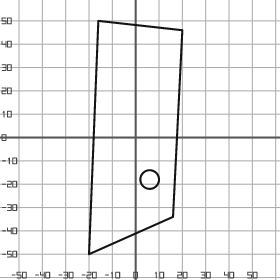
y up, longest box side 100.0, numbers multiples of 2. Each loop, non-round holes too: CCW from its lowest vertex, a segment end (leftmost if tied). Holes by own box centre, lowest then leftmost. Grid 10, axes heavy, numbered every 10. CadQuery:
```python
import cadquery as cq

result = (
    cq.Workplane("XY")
    .moveTo(-20.0, -50.0)
    .lineTo(16.0, -34.0)
    .lineTo(20.0, 46.0)
    .lineTo(-16.0, 50.0)
    .close()
    .moveTo(6.0, -18.0)
    .circle(4.0)
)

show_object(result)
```